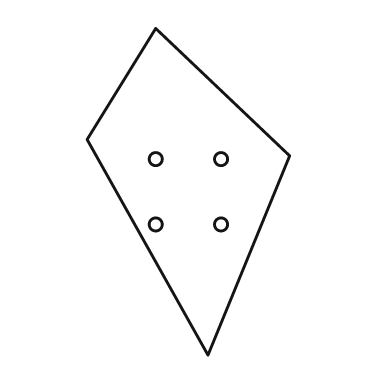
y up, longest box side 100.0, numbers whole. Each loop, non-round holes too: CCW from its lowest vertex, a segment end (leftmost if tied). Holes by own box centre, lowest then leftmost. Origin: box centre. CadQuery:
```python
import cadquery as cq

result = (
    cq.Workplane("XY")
    .moveTo(6.0, -50.0)
    .lineTo(31.0, 11.0)
    .lineTo(-10.0, 50.0)
    .lineTo(-31.0, 16.0)
    .close()
    .moveTo(-10.0, -10.0)
    .circle(2.0)
    .moveTo(10.0, -10.0)
    .circle(2.0)
    .moveTo(-10.0, 10.0)
    .circle(2.0)
    .moveTo(10.0, 10.0)
    .circle(2.0)
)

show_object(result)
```